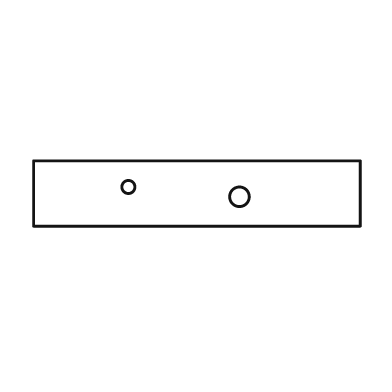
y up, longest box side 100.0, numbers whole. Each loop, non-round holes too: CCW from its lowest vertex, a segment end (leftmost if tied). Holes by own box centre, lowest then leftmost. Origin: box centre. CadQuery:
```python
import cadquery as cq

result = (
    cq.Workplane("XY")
    .moveTo(-50.0, -10.0)
    .lineTo(50.0, -10.0)
    .lineTo(50.0, 10.0)
    .lineTo(-50.0, 10.0)
    .close()
    .moveTo(13.0, -1.0)
    .circle(3.0)
    .moveTo(-21.0, 2.0)
    .circle(2.0)
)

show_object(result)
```